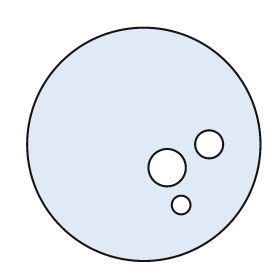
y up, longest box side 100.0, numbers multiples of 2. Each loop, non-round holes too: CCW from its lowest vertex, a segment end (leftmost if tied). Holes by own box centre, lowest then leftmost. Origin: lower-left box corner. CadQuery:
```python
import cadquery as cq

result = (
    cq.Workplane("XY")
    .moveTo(50.0, 50.0)
    .circle(50.0)
    .moveTo(66.0, 24.0)
    .circle(4.0)
    .moveTo(60.0, 40.0)
    .circle(8.0)
    .moveTo(78.0, 50.0)
    .circle(6.0)
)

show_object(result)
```